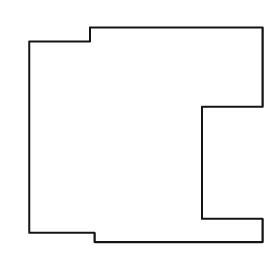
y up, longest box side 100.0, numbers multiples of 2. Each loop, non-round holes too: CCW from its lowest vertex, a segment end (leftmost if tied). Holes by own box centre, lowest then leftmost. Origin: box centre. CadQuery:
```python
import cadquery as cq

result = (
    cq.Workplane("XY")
    .moveTo(-22.0, -46.0)
    .lineTo(50.0, -46.0)
    .lineTo(50.0, -36.0)
    .lineTo(24.0, -36.0)
    .lineTo(24.0, 12.0)
    .lineTo(50.0, 12.0)
    .lineTo(50.0, 46.0)
    .lineTo(-24.0, 46.0)
    .lineTo(-24.0, 40.0)
    .lineTo(-50.0, 40.0)
    .lineTo(-50.0, -42.0)
    .lineTo(-22.0, -42.0)
    .close()
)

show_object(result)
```